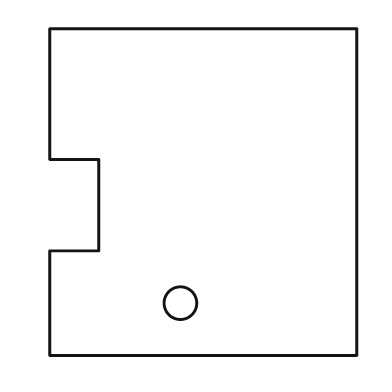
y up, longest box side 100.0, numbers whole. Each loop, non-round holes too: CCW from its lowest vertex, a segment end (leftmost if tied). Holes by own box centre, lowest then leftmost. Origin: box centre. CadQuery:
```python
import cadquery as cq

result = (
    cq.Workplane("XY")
    .moveTo(-47.0, -50.0)
    .lineTo(47.0, -50.0)
    .lineTo(47.0, 50.0)
    .lineTo(-47.0, 50.0)
    .lineTo(-47.0, 10.0)
    .lineTo(-32.0, 10.0)
    .lineTo(-32.0, -18.0)
    .lineTo(-47.0, -18.0)
    .close()
    .moveTo(-7.0, -34.0)
    .circle(5.0)
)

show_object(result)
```